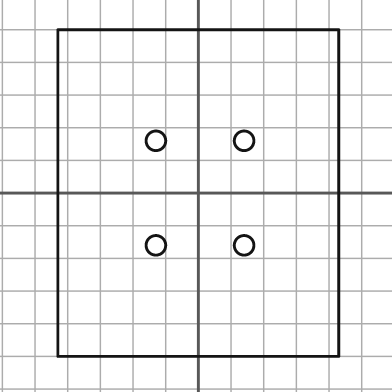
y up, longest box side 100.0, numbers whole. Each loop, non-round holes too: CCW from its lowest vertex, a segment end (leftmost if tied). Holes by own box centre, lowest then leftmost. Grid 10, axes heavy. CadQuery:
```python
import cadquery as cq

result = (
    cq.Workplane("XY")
    .moveTo(-43.0, -50.0)
    .lineTo(43.0, -50.0)
    .lineTo(43.0, 50.0)
    .lineTo(-43.0, 50.0)
    .close()
    .moveTo(-13.0, -16.0)
    .circle(3.0)
    .moveTo(14.0, -16.0)
    .circle(3.0)
    .moveTo(-13.0, 16.0)
    .circle(3.0)
    .moveTo(14.0, 16.0)
    .circle(3.0)
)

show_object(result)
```